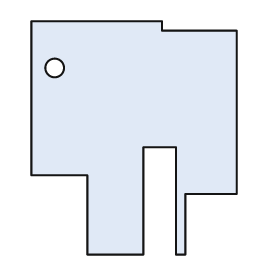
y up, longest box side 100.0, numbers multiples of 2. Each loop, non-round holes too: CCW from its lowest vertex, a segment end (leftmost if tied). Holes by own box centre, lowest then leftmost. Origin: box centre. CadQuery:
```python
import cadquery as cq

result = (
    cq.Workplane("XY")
    .moveTo(-20.0, -50.0)
    .lineTo(4.0, -50.0)
    .lineTo(4.0, -4.0)
    .lineTo(18.0, -4.0)
    .lineTo(18.0, -50.0)
    .lineTo(22.0, -50.0)
    .lineTo(22.0, -24.0)
    .lineTo(44.0, -24.0)
    .lineTo(44.0, 46.0)
    .lineTo(12.0, 46.0)
    .lineTo(12.0, 50.0)
    .lineTo(-44.0, 50.0)
    .lineTo(-44.0, -16.0)
    .lineTo(-20.0, -16.0)
    .close()
    .moveTo(-34.0, 30.0)
    .circle(4.0)
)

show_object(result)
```